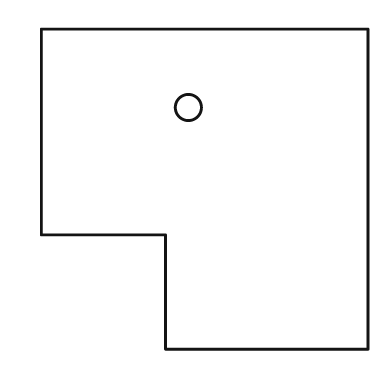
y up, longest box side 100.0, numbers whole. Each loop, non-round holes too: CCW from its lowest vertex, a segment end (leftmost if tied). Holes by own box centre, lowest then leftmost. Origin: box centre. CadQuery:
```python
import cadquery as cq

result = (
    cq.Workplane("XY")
    .moveTo(-12.0, -49.0)
    .lineTo(50.0, -49.0)
    .lineTo(50.0, 49.0)
    .lineTo(-50.0, 49.0)
    .lineTo(-50.0, -14.0)
    .lineTo(-12.0, -14.0)
    .close()
    .moveTo(-5.0, 25.0)
    .circle(4.0)
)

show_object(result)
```